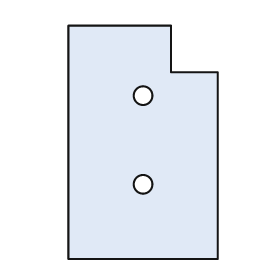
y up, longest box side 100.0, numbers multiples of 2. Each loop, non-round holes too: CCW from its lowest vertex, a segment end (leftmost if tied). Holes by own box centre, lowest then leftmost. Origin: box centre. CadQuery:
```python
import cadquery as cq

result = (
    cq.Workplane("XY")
    .moveTo(-32.0, -50.0)
    .lineTo(32.0, -50.0)
    .lineTo(32.0, 30.0)
    .lineTo(12.0, 30.0)
    .lineTo(12.0, 50.0)
    .lineTo(-32.0, 50.0)
    .close()
    .moveTo(0.0, -18.0)
    .circle(4.0)
    .moveTo(0.0, 20.0)
    .circle(4.0)
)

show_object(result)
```